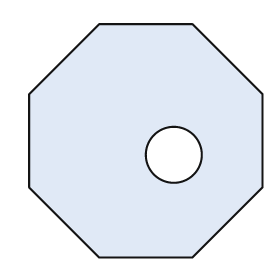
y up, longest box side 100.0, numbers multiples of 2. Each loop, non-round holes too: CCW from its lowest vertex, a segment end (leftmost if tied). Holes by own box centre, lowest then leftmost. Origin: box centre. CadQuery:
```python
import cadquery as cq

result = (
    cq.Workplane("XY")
    .moveTo(-20.0, -50.0)
    .lineTo(20.0, -50.0)
    .lineTo(50.0, -20.0)
    .lineTo(50.0, 20.0)
    .lineTo(20.0, 50.0)
    .lineTo(-20.0, 50.0)
    .lineTo(-50.0, 20.0)
    .lineTo(-50.0, -20.0)
    .close()
    .moveTo(12.0, -6.0)
    .circle(12.0)
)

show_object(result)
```